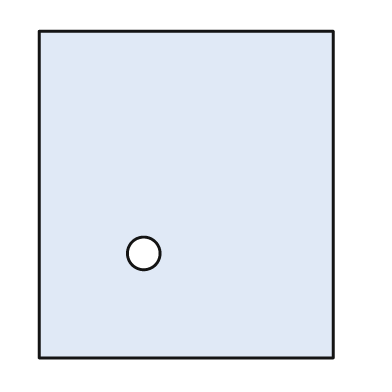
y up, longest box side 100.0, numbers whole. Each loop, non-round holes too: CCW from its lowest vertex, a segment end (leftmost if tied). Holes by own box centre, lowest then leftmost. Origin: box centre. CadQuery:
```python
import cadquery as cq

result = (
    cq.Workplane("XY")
    .moveTo(-45.0, -50.0)
    .lineTo(45.0, -50.0)
    .lineTo(45.0, 50.0)
    .lineTo(-45.0, 50.0)
    .close()
    .moveTo(-13.0, -18.0)
    .circle(5.0)
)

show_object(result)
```